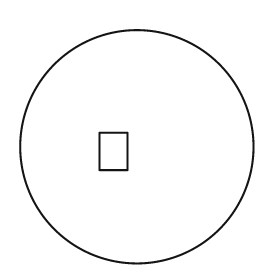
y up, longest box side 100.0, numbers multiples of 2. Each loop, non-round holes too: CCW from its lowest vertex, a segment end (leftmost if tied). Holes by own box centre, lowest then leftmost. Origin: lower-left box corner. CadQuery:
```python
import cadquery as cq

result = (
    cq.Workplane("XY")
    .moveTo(50.0, 50.0)
    .circle(50.0)
    .moveTo(34.0, 40.0)
    .lineTo(46.0, 40.0)
    .lineTo(46.0, 56.0)
    .lineTo(34.0, 56.0)
    .close()
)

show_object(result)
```